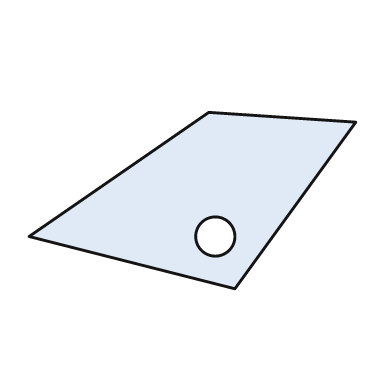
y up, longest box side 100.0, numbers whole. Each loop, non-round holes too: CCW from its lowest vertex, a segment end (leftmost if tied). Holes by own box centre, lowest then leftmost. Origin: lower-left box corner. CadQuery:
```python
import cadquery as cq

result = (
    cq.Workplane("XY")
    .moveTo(63.0, 0.0)
    .lineTo(100.0, 51.0)
    .lineTo(55.0, 54.0)
    .lineTo(0.0, 16.0)
    .close()
    .moveTo(57.0, 16.0)
    .circle(6.0)
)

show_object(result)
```